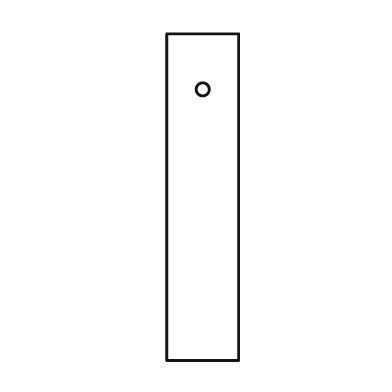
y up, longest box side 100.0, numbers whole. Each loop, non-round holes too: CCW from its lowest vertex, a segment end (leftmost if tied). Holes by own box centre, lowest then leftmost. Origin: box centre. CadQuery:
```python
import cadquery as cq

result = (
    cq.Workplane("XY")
    .moveTo(-11.0, -50.0)
    .lineTo(11.0, -50.0)
    .lineTo(11.0, 50.0)
    .lineTo(-11.0, 50.0)
    .close()
    .moveTo(0.0, 33.0)
    .circle(2.0)
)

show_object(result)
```